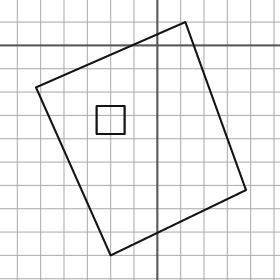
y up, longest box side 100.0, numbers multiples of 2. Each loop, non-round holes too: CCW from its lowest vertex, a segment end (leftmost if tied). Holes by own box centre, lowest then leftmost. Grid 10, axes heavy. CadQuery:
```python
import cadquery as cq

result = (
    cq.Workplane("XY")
    .moveTo(-20.0, -90.0)
    .lineTo(38.0, -62.0)
    .lineTo(12.0, 10.0)
    .lineTo(-52.0, -18.0)
    .close()
    .moveTo(-26.0, -38.0)
    .lineTo(-14.0, -38.0)
    .lineTo(-14.0, -26.0)
    .lineTo(-26.0, -26.0)
    .close()
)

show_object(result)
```